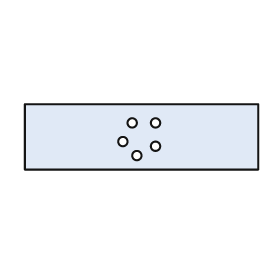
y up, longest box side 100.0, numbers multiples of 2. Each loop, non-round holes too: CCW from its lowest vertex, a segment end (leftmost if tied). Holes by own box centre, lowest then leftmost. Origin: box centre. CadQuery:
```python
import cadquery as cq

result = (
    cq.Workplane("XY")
    .moveTo(-50.0, -14.0)
    .lineTo(50.0, -14.0)
    .lineTo(50.0, 14.0)
    .lineTo(-50.0, 14.0)
    .close()
    .moveTo(-2.0, -8.0)
    .circle(2.0)
    .moveTo(6.0, -4.0)
    .circle(2.0)
    .moveTo(-8.0, -2.0)
    .circle(2.0)
    .moveTo(-4.0, 6.0)
    .circle(2.0)
    .moveTo(6.0, 6.0)
    .circle(2.0)
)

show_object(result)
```